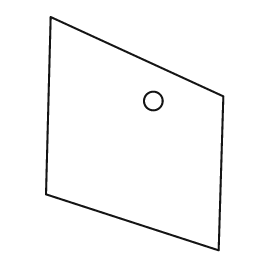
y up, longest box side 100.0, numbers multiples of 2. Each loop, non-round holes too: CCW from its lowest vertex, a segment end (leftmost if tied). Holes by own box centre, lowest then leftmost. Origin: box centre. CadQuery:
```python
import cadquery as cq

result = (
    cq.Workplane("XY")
    .moveTo(36.0, -50.0)
    .lineTo(38.0, 16.0)
    .lineTo(-36.0, 50.0)
    .lineTo(-38.0, -26.0)
    .close()
    .moveTo(8.0, 14.0)
    .circle(4.0)
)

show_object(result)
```